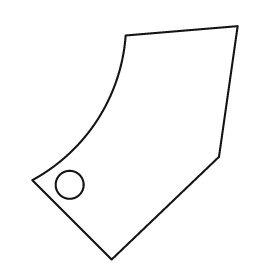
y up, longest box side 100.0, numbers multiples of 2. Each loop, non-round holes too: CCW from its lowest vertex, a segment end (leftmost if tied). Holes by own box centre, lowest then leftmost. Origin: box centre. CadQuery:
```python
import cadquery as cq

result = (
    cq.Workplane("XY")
    .moveTo(-10.0, -50.0)
    .lineTo(36.0, -6.0)
    .lineTo(44.0, 50.0)
    .lineTo(-4.0, 46.0)
    .threePointArc((-16.0, 10.0), (-44.0, -16.0))
    .close()
    .moveTo(-28.0, -18.0)
    .circle(6.0)
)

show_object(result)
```